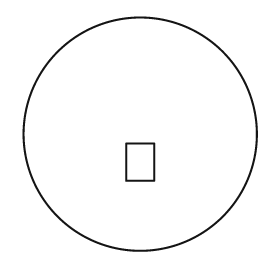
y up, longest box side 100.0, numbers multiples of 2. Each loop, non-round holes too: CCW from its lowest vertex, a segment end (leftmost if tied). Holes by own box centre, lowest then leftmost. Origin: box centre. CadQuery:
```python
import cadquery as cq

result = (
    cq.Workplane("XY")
    .moveTo(0.0, 0.0)
    .circle(50.0)
    .moveTo(-6.0, -20.0)
    .lineTo(6.0, -20.0)
    .lineTo(6.0, -4.0)
    .lineTo(-6.0, -4.0)
    .close()
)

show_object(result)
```